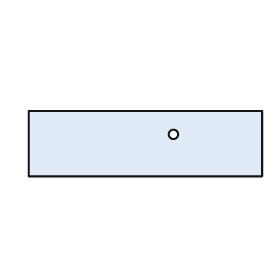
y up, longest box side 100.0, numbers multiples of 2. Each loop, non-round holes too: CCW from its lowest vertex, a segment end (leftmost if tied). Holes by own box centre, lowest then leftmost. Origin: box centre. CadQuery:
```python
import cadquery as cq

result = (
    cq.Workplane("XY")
    .moveTo(-50.0, -14.0)
    .lineTo(50.0, -14.0)
    .lineTo(50.0, 14.0)
    .lineTo(-50.0, 14.0)
    .close()
    .moveTo(12.0, 4.0)
    .circle(2.0)
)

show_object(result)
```